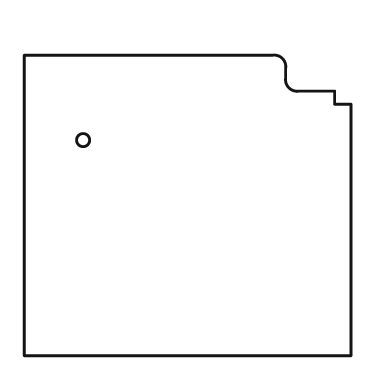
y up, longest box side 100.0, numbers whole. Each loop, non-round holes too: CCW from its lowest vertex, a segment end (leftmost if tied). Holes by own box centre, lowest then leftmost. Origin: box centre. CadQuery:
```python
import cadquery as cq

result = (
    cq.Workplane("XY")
    .moveTo(-50.0, -46.0)
    .lineTo(50.0, -46.0)
    .lineTo(50.0, 31.0)
    .lineTo(45.0, 31.0)
    .lineTo(45.0, 35.0)
    .lineTo(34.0, 35.0)
    .threePointArc((31.0, 36.0), (30.0, 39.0))
    .lineTo(30.0, 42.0)
    .threePointArc((29.0, 45.0), (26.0, 46.0))
    .lineTo(-50.0, 46.0)
    .close()
    .moveTo(-32.0, 20.0)
    .circle(2.0)
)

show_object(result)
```